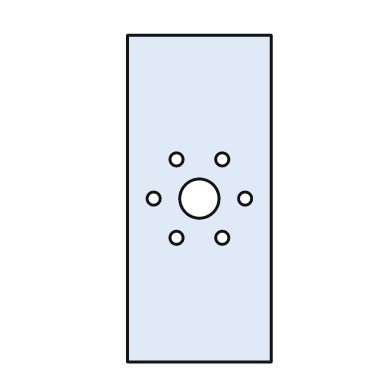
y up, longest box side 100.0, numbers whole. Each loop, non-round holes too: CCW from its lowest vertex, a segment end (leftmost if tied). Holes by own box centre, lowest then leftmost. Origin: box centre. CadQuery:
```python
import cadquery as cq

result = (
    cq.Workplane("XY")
    .moveTo(-22.0, -50.0)
    .lineTo(22.0, -50.0)
    .lineTo(22.0, 50.0)
    .lineTo(-22.0, 50.0)
    .close()
    .moveTo(-7.0, -12.0)
    .circle(2.0)
    .moveTo(7.0, -12.0)
    .circle(2.0)
    .moveTo(-14.0, 0.0)
    .circle(2.0)
    .moveTo(0.0, 0.0)
    .circle(6.0)
    .moveTo(14.0, 0.0)
    .circle(2.0)
    .moveTo(-7.0, 12.0)
    .circle(2.0)
    .moveTo(7.0, 12.0)
    .circle(2.0)
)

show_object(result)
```